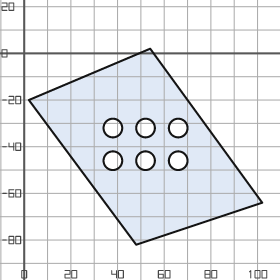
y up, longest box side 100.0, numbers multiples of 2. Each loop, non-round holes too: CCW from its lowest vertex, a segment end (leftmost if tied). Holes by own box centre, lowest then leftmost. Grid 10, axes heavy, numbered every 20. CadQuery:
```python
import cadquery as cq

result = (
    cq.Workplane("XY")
    .moveTo(48.0, -82.0)
    .lineTo(102.0, -64.0)
    .lineTo(54.0, 2.0)
    .lineTo(2.0, -20.0)
    .close()
    .moveTo(38.0, -46.0)
    .circle(4.0)
    .moveTo(52.0, -46.0)
    .circle(4.0)
    .moveTo(66.0, -46.0)
    .circle(4.0)
    .moveTo(38.0, -32.0)
    .circle(4.0)
    .moveTo(52.0, -32.0)
    .circle(4.0)
    .moveTo(66.0, -32.0)
    .circle(4.0)
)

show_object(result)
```